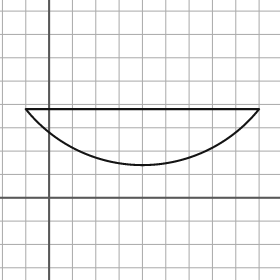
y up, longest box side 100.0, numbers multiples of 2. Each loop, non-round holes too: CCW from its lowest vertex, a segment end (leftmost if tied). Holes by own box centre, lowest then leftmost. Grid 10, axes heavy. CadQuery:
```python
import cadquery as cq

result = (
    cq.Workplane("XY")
    .moveTo(-10.0, 38.0)
    .threePointArc((40.0, 14.0), (90.0, 38.0))
    .close()
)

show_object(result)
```